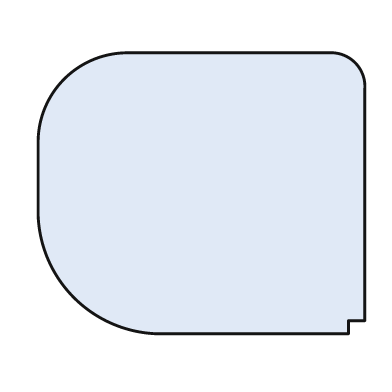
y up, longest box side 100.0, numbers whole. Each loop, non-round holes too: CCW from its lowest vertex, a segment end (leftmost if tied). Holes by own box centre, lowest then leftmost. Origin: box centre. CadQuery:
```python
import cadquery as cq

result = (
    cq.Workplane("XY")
    .moveTo(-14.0, -43.0)
    .lineTo(45.0, -43.0)
    .lineTo(45.0, -39.0)
    .lineTo(50.0, -39.0)
    .lineTo(50.0, 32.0)
    .threePointArc((47.0, 40.0), (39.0, 43.0))
    .lineTo(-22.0, 43.0)
    .threePointArc((-42.0, 35.0), (-50.0, 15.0))
    .lineTo(-50.0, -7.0)
    .threePointArc((-39.0, -32.0), (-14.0, -43.0))
    .close()
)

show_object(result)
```